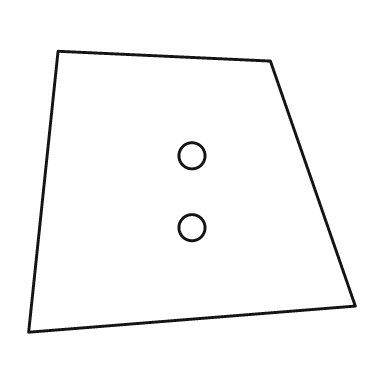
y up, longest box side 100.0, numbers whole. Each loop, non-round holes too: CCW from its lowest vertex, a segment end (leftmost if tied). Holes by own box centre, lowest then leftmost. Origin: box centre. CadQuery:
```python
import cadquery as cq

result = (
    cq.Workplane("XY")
    .moveTo(-50.0, -43.0)
    .lineTo(50.0, -35.0)
    .lineTo(24.0, 40.0)
    .lineTo(-41.0, 43.0)
    .close()
    .moveTo(0.0, -11.0)
    .circle(4.0)
    .moveTo(0.0, 11.0)
    .circle(4.0)
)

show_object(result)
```